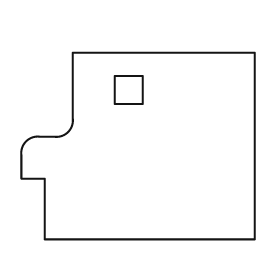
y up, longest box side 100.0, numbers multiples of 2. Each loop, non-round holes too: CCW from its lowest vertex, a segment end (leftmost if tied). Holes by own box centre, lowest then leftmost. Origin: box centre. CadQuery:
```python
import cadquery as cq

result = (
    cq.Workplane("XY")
    .moveTo(-40.0, -40.0)
    .lineTo(50.0, -40.0)
    .lineTo(50.0, 40.0)
    .lineTo(-28.0, 40.0)
    .lineTo(-28.0, 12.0)
    .threePointArc((-30.0, 6.0), (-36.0, 4.0))
    .lineTo(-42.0, 4.0)
    .threePointArc((-48.0, 2.0), (-50.0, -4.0))
    .lineTo(-50.0, -14.0)
    .lineTo(-40.0, -14.0)
    .close()
    .moveTo(-10.0, 18.0)
    .lineTo(2.0, 18.0)
    .lineTo(2.0, 30.0)
    .lineTo(-10.0, 30.0)
    .close()
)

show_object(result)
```